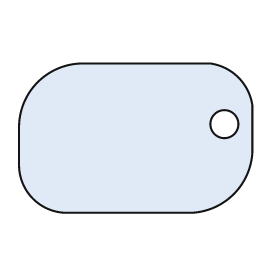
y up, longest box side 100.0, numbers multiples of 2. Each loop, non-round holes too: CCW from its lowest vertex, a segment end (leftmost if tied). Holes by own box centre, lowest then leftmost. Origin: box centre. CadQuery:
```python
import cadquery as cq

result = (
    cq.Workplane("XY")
    .moveTo(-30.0, -32.0)
    .lineTo(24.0, -32.0)
    .threePointArc((42.0, -24.0), (50.0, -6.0))
    .lineTo(50.0, 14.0)
    .threePointArc((44.0, 26.0), (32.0, 32.0))
    .lineTo(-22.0, 32.0)
    .threePointArc((-42.0, 24.0), (-50.0, 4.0))
    .lineTo(-50.0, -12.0)
    .threePointArc((-44.0, -26.0), (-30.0, -32.0))
    .close()
    .moveTo(38.0, 6.0)
    .circle(6.0)
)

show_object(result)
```